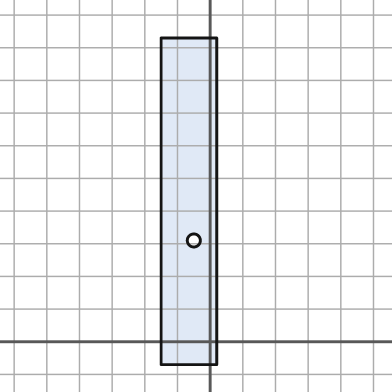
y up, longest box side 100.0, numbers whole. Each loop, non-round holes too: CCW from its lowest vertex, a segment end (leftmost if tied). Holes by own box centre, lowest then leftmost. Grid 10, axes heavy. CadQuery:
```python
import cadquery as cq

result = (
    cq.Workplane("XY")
    .moveTo(-15.0, -7.0)
    .lineTo(2.0, -7.0)
    .lineTo(2.0, 93.0)
    .lineTo(-15.0, 93.0)
    .close()
    .moveTo(-5.0, 31.0)
    .circle(2.0)
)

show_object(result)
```